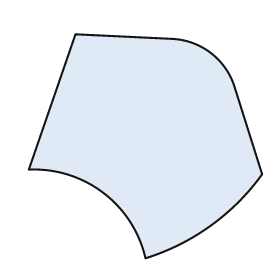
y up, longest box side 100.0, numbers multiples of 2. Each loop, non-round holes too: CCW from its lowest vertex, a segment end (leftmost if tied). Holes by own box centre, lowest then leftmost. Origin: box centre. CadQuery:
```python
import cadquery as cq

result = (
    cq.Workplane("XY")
    .moveTo(0.0, -48.0)
    .threePointArc((28.0, -34.0), (50.0, -12.0))
    .lineTo(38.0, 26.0)
    .threePointArc((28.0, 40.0), (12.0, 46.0))
    .lineTo(-30.0, 48.0)
    .lineTo(-50.0, -10.0)
    .threePointArc((-18.0, -20.0), (0.0, -48.0))
    .close()
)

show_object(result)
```